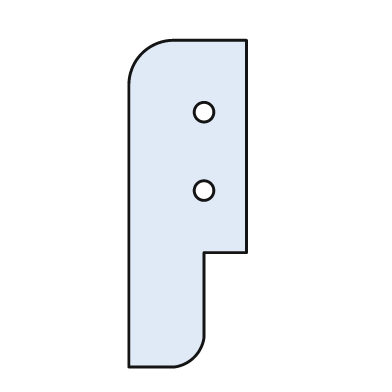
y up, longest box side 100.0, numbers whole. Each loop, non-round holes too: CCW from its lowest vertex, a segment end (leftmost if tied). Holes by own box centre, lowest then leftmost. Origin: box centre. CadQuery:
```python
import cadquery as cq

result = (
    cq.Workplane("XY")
    .moveTo(-18.0, -50.0)
    .lineTo(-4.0, -50.0)
    .threePointArc((2.0, -47.0), (5.0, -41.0))
    .lineTo(5.0, -15.0)
    .lineTo(18.0, -15.0)
    .lineTo(18.0, 50.0)
    .lineTo(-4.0, 50.0)
    .threePointArc((-14.0, 46.0), (-18.0, 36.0))
    .close()
    .moveTo(5.0, 4.0)
    .circle(3.0)
    .moveTo(5.0, 28.0)
    .circle(3.0)
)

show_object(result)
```